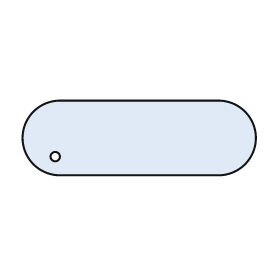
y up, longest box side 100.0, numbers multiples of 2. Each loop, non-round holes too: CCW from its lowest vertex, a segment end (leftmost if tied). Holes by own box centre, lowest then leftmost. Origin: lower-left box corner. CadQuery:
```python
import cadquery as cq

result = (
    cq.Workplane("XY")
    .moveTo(16.0, 0.0)
    .lineTo(84.0, 0.0)
    .threePointArc((100.0, 16.0), (84.0, 32.0))
    .lineTo(16.0, 32.0)
    .threePointArc((0.0, 16.0), (16.0, 0.0))
    .close()
    .moveTo(14.0, 8.0)
    .circle(2.0)
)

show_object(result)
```